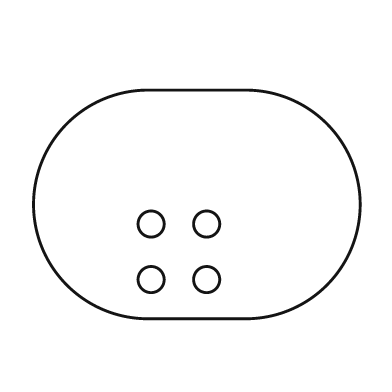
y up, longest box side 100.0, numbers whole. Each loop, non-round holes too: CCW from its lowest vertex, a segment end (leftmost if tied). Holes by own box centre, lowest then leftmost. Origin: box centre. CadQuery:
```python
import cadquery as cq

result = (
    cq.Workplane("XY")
    .moveTo(-15.0, -35.0)
    .lineTo(15.0, -35.0)
    .threePointArc((50.0, 0.0), (15.0, 35.0))
    .lineTo(-15.0, 35.0)
    .threePointArc((-50.0, 0.0), (-15.0, -35.0))
    .close()
    .moveTo(-14.0, -23.0)
    .circle(4.0)
    .moveTo(3.0, -23.0)
    .circle(4.0)
    .moveTo(-14.0, -6.0)
    .circle(4.0)
    .moveTo(3.0, -6.0)
    .circle(4.0)
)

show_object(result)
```